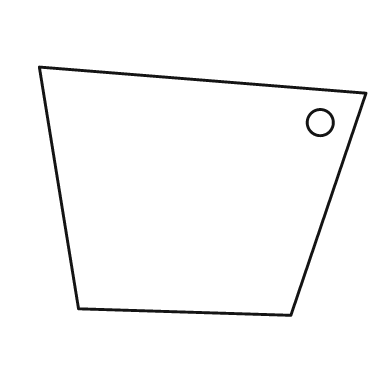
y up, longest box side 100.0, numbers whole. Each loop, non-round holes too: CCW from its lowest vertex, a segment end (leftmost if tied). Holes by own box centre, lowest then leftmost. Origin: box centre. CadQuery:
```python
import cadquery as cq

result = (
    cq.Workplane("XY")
    .moveTo(27.0, -38.0)
    .lineTo(50.0, 30.0)
    .lineTo(-50.0, 38.0)
    .lineTo(-38.0, -36.0)
    .close()
    .moveTo(36.0, 21.0)
    .circle(4.0)
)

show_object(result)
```